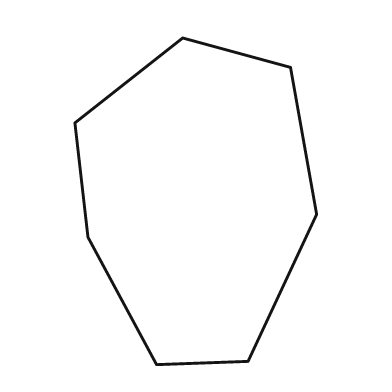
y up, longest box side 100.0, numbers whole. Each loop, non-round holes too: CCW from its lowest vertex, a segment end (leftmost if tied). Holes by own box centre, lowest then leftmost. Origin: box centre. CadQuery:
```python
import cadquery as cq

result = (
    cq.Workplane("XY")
    .moveTo(-12.0, -50.0)
    .lineTo(16.0, -49.0)
    .lineTo(37.0, -4.0)
    .lineTo(29.0, 41.0)
    .lineTo(-4.0, 50.0)
    .lineTo(-37.0, 24.0)
    .lineTo(-33.0, -11.0)
    .close()
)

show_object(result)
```